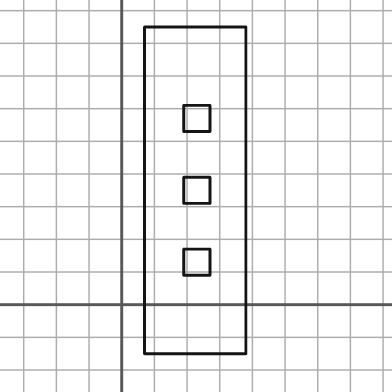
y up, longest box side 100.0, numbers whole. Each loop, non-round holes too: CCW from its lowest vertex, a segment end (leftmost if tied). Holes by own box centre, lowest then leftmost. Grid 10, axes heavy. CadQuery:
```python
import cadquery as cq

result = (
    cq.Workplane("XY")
    .moveTo(7.0, -15.0)
    .lineTo(38.0, -15.0)
    .lineTo(38.0, 85.0)
    .lineTo(7.0, 85.0)
    .close()
    .moveTo(19.0, 9.0)
    .lineTo(27.0, 9.0)
    .lineTo(27.0, 17.0)
    .lineTo(19.0, 17.0)
    .close()
    .moveTo(19.0, 31.0)
    .lineTo(27.0, 31.0)
    .lineTo(27.0, 39.0)
    .lineTo(19.0, 39.0)
    .close()
    .moveTo(19.0, 53.0)
    .lineTo(27.0, 53.0)
    .lineTo(27.0, 61.0)
    .lineTo(19.0, 61.0)
    .close()
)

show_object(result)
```